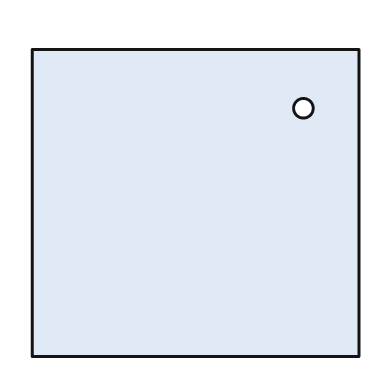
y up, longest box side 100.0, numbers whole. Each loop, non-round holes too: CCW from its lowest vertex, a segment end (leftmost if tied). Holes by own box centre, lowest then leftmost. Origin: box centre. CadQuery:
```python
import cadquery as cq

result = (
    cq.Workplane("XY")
    .moveTo(-50.0, -47.0)
    .lineTo(50.0, -47.0)
    .lineTo(50.0, 47.0)
    .lineTo(-50.0, 47.0)
    .close()
    .moveTo(33.0, 29.0)
    .circle(3.0)
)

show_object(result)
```